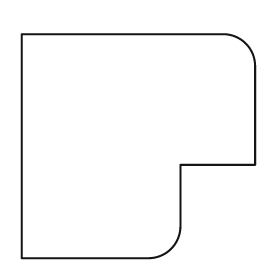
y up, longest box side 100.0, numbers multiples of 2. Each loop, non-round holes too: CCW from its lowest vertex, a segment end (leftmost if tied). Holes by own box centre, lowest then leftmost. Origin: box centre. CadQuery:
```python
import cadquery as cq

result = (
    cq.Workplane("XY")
    .moveTo(-50.0, -48.0)
    .lineTo(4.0, -48.0)
    .threePointArc((14.0, -44.0), (18.0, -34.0))
    .lineTo(18.0, -8.0)
    .lineTo(50.0, -8.0)
    .lineTo(50.0, 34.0)
    .threePointArc((46.0, 44.0), (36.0, 48.0))
    .lineTo(-50.0, 48.0)
    .close()
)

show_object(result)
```